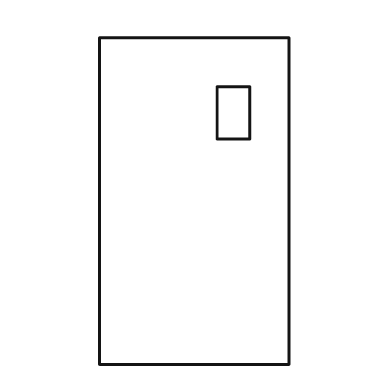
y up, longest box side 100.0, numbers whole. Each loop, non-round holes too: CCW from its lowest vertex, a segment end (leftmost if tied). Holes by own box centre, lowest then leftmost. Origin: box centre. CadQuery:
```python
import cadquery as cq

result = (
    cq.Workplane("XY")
    .moveTo(-29.0, -50.0)
    .lineTo(29.0, -50.0)
    .lineTo(29.0, 50.0)
    .lineTo(-29.0, 50.0)
    .close()
    .moveTo(7.0, 19.0)
    .lineTo(17.0, 19.0)
    .lineTo(17.0, 35.0)
    .lineTo(7.0, 35.0)
    .close()
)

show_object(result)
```